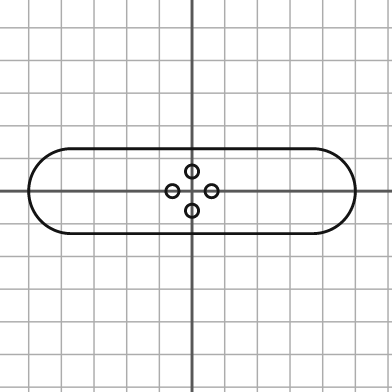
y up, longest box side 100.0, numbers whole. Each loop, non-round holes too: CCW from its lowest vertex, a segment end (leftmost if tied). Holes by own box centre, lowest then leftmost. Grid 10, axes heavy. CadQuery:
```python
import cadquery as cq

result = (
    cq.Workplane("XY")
    .moveTo(-37.0, -13.0)
    .lineTo(37.0, -13.0)
    .threePointArc((50.0, 0.0), (37.0, 13.0))
    .lineTo(-37.0, 13.0)
    .threePointArc((-50.0, 0.0), (-37.0, -13.0))
    .close()
    .moveTo(0.0, -6.0)
    .circle(2.0)
    .moveTo(-6.0, 0.0)
    .circle(2.0)
    .moveTo(6.0, 0.0)
    .circle(2.0)
    .moveTo(0.0, 6.0)
    .circle(2.0)
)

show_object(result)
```